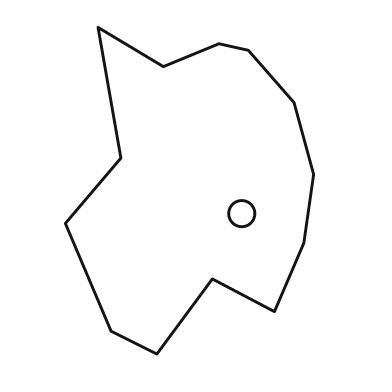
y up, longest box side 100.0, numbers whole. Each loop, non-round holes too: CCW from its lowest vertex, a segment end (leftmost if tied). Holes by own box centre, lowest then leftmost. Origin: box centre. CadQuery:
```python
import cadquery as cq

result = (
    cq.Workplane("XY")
    .moveTo(-10.0, -50.0)
    .lineTo(7.0, -27.0)
    .lineTo(26.0, -37.0)
    .lineTo(35.0, -16.0)
    .lineTo(38.0, 5.0)
    .lineTo(32.0, 27.0)
    .lineTo(18.0, 43.0)
    .lineTo(9.0, 45.0)
    .lineTo(-8.0, 38.0)
    .lineTo(-28.0, 50.0)
    .lineTo(-21.0, 10.0)
    .lineTo(-38.0, -10.0)
    .lineTo(-24.0, -43.0)
    .close()
    .moveTo(16.0, -7.0)
    .circle(4.0)
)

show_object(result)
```